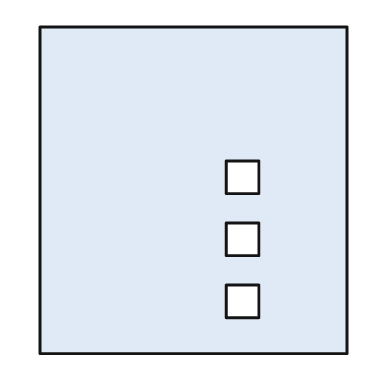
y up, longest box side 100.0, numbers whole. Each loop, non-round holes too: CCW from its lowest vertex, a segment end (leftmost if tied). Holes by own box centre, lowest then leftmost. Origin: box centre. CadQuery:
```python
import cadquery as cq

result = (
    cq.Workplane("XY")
    .moveTo(-47.0, -50.0)
    .lineTo(47.0, -50.0)
    .lineTo(47.0, 50.0)
    .lineTo(-47.0, 50.0)
    .close()
    .moveTo(10.0, -39.0)
    .lineTo(20.0, -39.0)
    .lineTo(20.0, -29.0)
    .lineTo(10.0, -29.0)
    .close()
    .moveTo(10.0, -20.0)
    .lineTo(20.0, -20.0)
    .lineTo(20.0, -10.0)
    .lineTo(10.0, -10.0)
    .close()
    .moveTo(10.0, -1.0)
    .lineTo(20.0, -1.0)
    .lineTo(20.0, 9.0)
    .lineTo(10.0, 9.0)
    .close()
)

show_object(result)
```